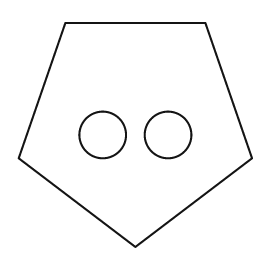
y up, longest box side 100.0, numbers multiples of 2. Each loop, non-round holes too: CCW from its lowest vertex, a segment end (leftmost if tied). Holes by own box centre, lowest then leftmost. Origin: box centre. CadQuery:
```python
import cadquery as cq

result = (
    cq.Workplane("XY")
    .moveTo(0.0, -48.0)
    .lineTo(50.0, -10.0)
    .lineTo(30.0, 48.0)
    .lineTo(-30.0, 48.0)
    .lineTo(-50.0, -10.0)
    .close()
    .moveTo(-14.0, 0.0)
    .circle(10.0)
    .moveTo(14.0, 0.0)
    .circle(10.0)
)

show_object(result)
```